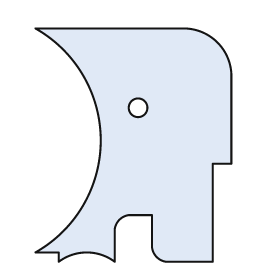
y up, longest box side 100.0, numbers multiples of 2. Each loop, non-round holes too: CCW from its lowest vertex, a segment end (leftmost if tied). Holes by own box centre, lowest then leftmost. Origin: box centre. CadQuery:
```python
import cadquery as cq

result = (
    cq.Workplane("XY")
    .moveTo(-32.0, -50.0)
    .threePointArc((-20.0, -46.0), (-8.0, -50.0))
    .lineTo(-8.0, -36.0)
    .threePointArc((-6.0, -32.0), (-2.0, -30.0))
    .lineTo(8.0, -30.0)
    .lineTo(8.0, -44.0)
    .threePointArc((10.0, -48.0), (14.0, -50.0))
    .lineTo(34.0, -50.0)
    .lineTo(34.0, -8.0)
    .lineTo(42.0, -8.0)
    .lineTo(42.0, 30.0)
    .threePointArc((36.0, 44.0), (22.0, 50.0))
    .lineTo(-42.0, 50.0)
    .threePointArc((-14.0, 2.0), (-42.0, -46.0))
    .lineTo(-32.0, -46.0)
    .close()
    .moveTo(2.0, 16.0)
    .circle(4.0)
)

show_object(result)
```